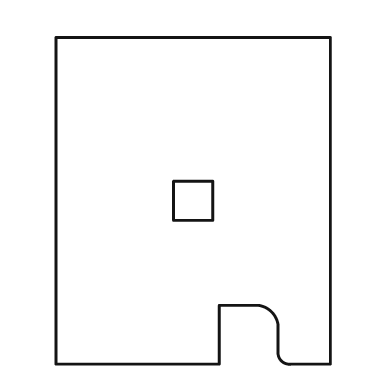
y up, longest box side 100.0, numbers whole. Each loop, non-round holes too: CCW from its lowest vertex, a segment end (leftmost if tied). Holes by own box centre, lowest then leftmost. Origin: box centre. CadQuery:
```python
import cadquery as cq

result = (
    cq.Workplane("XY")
    .moveTo(-42.0, -50.0)
    .lineTo(8.0, -50.0)
    .lineTo(8.0, -32.0)
    .lineTo(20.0, -32.0)
    .threePointArc((24.0, -34.0), (26.0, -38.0))
    .lineTo(26.0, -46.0)
    .threePointArc((27.0, -49.0), (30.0, -50.0))
    .lineTo(42.0, -50.0)
    .lineTo(42.0, 50.0)
    .lineTo(-42.0, 50.0)
    .close()
    .moveTo(-6.0, -6.0)
    .lineTo(6.0, -6.0)
    .lineTo(6.0, 6.0)
    .lineTo(-6.0, 6.0)
    .close()
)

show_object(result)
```